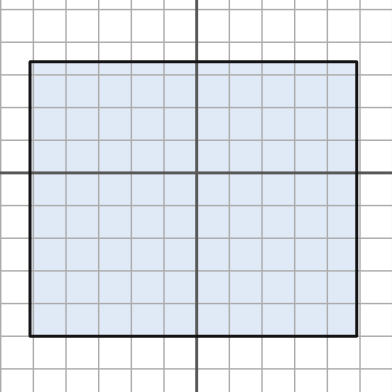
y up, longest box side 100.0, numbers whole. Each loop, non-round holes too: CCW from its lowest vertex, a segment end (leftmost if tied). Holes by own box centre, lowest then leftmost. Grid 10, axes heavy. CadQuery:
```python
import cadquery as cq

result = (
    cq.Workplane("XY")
    .moveTo(-51.0, -50.0)
    .lineTo(49.0, -50.0)
    .lineTo(49.0, 34.0)
    .lineTo(-51.0, 34.0)
    .close()
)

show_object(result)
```